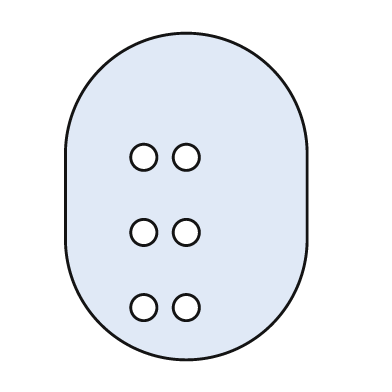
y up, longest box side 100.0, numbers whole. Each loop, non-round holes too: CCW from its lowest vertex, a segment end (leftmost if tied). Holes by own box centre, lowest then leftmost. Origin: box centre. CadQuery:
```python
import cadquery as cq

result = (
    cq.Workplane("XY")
    .moveTo(-37.0, -13.0)
    .threePointArc((0.0, -50.0), (37.0, -13.0))
    .lineTo(37.0, 13.0)
    .threePointArc((0.0, 50.0), (-37.0, 13.0))
    .close()
    .moveTo(-13.0, -34.0)
    .circle(4.0)
    .moveTo(0.0, -34.0)
    .circle(4.0)
    .moveTo(-13.0, -11.0)
    .circle(4.0)
    .moveTo(0.0, -11.0)
    .circle(4.0)
    .moveTo(-13.0, 12.0)
    .circle(4.0)
    .moveTo(0.0, 12.0)
    .circle(4.0)
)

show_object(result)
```